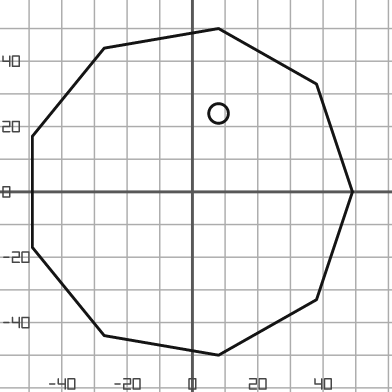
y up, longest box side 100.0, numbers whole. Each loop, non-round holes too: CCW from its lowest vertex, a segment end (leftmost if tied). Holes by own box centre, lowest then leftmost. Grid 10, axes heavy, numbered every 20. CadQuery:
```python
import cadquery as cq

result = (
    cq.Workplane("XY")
    .moveTo(8.0, -50.0)
    .lineTo(38.0, -33.0)
    .lineTo(49.0, 0.0)
    .lineTo(38.0, 33.0)
    .lineTo(8.0, 50.0)
    .lineTo(-27.0, 44.0)
    .lineTo(-49.0, 17.0)
    .lineTo(-49.0, -17.0)
    .lineTo(-27.0, -44.0)
    .close()
    .moveTo(8.0, 24.0)
    .circle(3.0)
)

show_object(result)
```